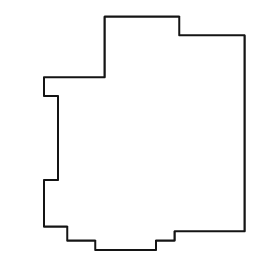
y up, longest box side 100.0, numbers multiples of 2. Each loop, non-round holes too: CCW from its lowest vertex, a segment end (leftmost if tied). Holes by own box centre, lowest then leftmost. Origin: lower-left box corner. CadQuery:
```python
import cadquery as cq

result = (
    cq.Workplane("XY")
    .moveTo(22.0, 0.0)
    .lineTo(48.0, 0.0)
    .lineTo(48.0, 4.0)
    .lineTo(56.0, 4.0)
    .lineTo(56.0, 8.0)
    .lineTo(86.0, 8.0)
    .lineTo(86.0, 92.0)
    .lineTo(58.0, 92.0)
    .lineTo(58.0, 100.0)
    .lineTo(26.0, 100.0)
    .lineTo(26.0, 74.0)
    .lineTo(0.0, 74.0)
    .lineTo(0.0, 66.0)
    .lineTo(6.0, 66.0)
    .lineTo(6.0, 30.0)
    .lineTo(0.0, 30.0)
    .lineTo(0.0, 10.0)
    .lineTo(10.0, 10.0)
    .lineTo(10.0, 4.0)
    .lineTo(22.0, 4.0)
    .close()
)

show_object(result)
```